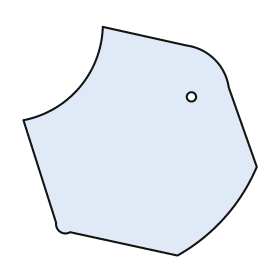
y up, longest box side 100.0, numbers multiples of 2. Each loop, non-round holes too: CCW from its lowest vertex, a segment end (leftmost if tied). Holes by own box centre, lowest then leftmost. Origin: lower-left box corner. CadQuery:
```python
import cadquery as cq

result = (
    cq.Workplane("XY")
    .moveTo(66.0, 0.0)
    .threePointArc((86.0, 16.0), (100.0, 38.0))
    .lineTo(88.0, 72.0)
    .threePointArc((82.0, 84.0), (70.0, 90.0))
    .lineTo(34.0, 98.0)
    .threePointArc((24.0, 72.0), (0.0, 58.0))
    .lineTo(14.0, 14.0)
    .threePointArc((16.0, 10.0), (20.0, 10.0))
    .close()
    .moveTo(72.0, 68.0)
    .circle(2.0)
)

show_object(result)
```